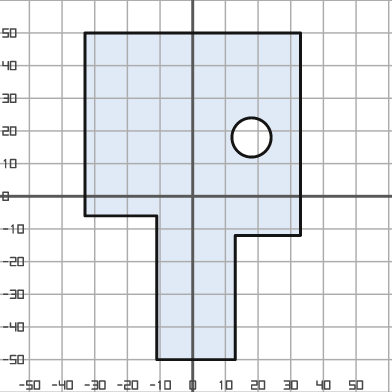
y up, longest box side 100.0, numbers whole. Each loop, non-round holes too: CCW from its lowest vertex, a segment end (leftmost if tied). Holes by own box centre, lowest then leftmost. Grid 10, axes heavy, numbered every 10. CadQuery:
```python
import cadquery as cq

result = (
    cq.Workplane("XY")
    .moveTo(-11.0, -50.0)
    .lineTo(13.0, -50.0)
    .lineTo(13.0, -12.0)
    .lineTo(33.0, -12.0)
    .lineTo(33.0, 50.0)
    .lineTo(-33.0, 50.0)
    .lineTo(-33.0, -6.0)
    .lineTo(-11.0, -6.0)
    .close()
    .moveTo(18.0, 18.0)
    .circle(6.0)
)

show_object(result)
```